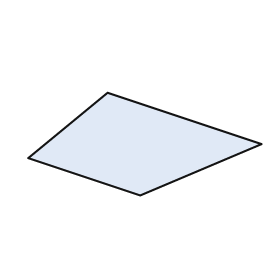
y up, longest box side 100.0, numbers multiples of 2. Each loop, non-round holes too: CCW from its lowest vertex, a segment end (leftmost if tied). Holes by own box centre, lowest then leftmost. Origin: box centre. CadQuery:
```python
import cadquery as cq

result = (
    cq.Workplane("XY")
    .moveTo(-2.0, -22.0)
    .lineTo(50.0, 0.0)
    .lineTo(-16.0, 22.0)
    .lineTo(-50.0, -6.0)
    .close()
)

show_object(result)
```